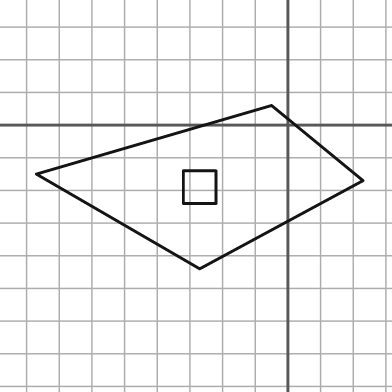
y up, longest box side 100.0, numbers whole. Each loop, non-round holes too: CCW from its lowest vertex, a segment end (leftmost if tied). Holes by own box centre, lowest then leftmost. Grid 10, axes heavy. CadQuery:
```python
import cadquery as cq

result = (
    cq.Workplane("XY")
    .moveTo(-27.0, -44.0)
    .lineTo(23.0, -17.0)
    .lineTo(-5.0, 6.0)
    .lineTo(-77.0, -15.0)
    .close()
    .moveTo(-32.0, -24.0)
    .lineTo(-22.0, -24.0)
    .lineTo(-22.0, -14.0)
    .lineTo(-32.0, -14.0)
    .close()
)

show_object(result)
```